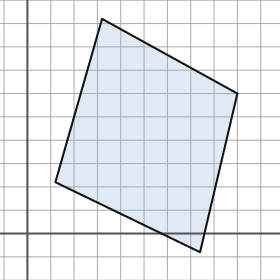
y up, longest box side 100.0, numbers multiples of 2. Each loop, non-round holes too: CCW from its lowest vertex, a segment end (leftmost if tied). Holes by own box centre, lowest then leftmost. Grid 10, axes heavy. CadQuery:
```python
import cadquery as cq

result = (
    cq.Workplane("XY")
    .moveTo(74.0, -8.0)
    .lineTo(90.0, 60.0)
    .lineTo(32.0, 92.0)
    .lineTo(12.0, 22.0)
    .close()
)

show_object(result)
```